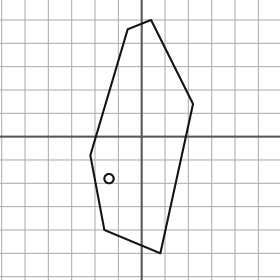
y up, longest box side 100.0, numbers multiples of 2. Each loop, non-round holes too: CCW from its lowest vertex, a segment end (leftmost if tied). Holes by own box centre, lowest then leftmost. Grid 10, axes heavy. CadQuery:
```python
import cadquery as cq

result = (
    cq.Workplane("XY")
    .moveTo(8.0, -50.0)
    .lineTo(22.0, 14.0)
    .lineTo(4.0, 50.0)
    .lineTo(-6.0, 46.0)
    .lineTo(-22.0, -8.0)
    .lineTo(-16.0, -40.0)
    .close()
    .moveTo(-14.0, -18.0)
    .circle(2.0)
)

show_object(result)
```